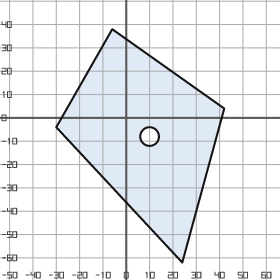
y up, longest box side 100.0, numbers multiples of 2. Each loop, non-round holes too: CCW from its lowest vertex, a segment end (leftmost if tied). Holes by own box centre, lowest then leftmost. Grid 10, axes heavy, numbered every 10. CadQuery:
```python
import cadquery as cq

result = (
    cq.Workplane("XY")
    .moveTo(24.0, -62.0)
    .lineTo(42.0, 4.0)
    .lineTo(-6.0, 38.0)
    .lineTo(-30.0, -4.0)
    .close()
    .moveTo(10.0, -8.0)
    .circle(4.0)
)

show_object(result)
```